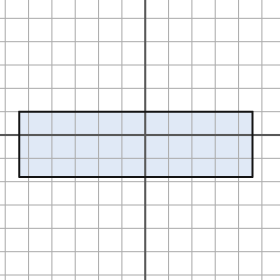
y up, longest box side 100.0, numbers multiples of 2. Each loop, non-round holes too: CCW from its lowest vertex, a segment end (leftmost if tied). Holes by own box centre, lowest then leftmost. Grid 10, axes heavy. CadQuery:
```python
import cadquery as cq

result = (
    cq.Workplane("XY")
    .moveTo(-54.0, -18.0)
    .lineTo(46.0, -18.0)
    .lineTo(46.0, 10.0)
    .lineTo(-54.0, 10.0)
    .close()
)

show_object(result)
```